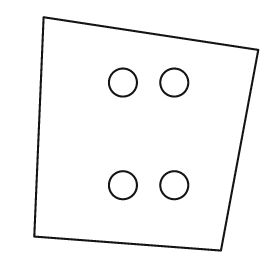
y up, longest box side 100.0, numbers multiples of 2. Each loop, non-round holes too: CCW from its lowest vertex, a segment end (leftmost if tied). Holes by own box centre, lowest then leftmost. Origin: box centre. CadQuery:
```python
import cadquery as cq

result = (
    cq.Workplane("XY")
    .moveTo(32.0, -50.0)
    .lineTo(48.0, 36.0)
    .lineTo(-44.0, 50.0)
    .lineTo(-48.0, -44.0)
    .close()
    .moveTo(-10.0, -22.0)
    .circle(6.0)
    .moveTo(12.0, -22.0)
    .circle(6.0)
    .moveTo(-10.0, 22.0)
    .circle(6.0)
    .moveTo(12.0, 22.0)
    .circle(6.0)
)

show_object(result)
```